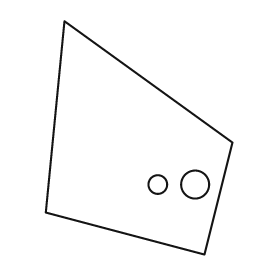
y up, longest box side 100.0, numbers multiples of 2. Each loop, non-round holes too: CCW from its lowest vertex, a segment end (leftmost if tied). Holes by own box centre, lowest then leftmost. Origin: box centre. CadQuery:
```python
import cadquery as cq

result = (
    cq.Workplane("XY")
    .moveTo(28.0, -50.0)
    .lineTo(40.0, -2.0)
    .lineTo(-32.0, 50.0)
    .lineTo(-40.0, -32.0)
    .close()
    .moveTo(8.0, -20.0)
    .circle(4.0)
    .moveTo(24.0, -20.0)
    .circle(6.0)
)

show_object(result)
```